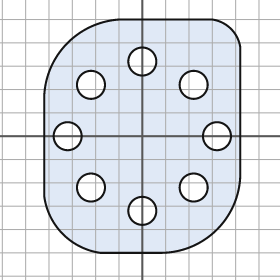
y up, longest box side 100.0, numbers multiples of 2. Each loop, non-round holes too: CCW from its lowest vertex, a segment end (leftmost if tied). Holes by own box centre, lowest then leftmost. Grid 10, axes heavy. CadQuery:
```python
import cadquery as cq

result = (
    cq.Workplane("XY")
    .moveTo(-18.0, -50.0)
    .lineTo(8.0, -50.0)
    .threePointArc((32.0, -40.0), (42.0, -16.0))
    .lineTo(42.0, 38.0)
    .threePointArc((38.0, 46.0), (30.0, 50.0))
    .lineTo(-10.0, 50.0)
    .threePointArc((-32.0, 40.0), (-42.0, 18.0))
    .lineTo(-42.0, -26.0)
    .threePointArc((-34.0, -42.0), (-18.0, -50.0))
    .close()
    .moveTo(0.0, -32.0)
    .circle(6.0)
    .moveTo(-22.0, -22.0)
    .circle(6.0)
    .moveTo(22.0, -22.0)
    .circle(6.0)
    .moveTo(-32.0, 0.0)
    .circle(6.0)
    .moveTo(32.0, 0.0)
    .circle(6.0)
    .moveTo(-22.0, 22.0)
    .circle(6.0)
    .moveTo(22.0, 22.0)
    .circle(6.0)
    .moveTo(0.0, 32.0)
    .circle(6.0)
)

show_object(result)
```